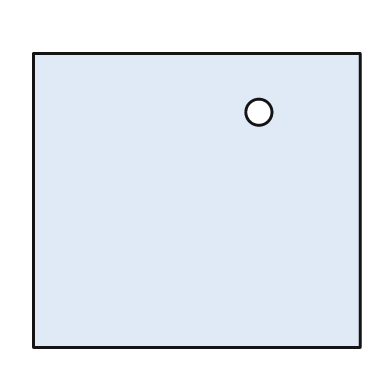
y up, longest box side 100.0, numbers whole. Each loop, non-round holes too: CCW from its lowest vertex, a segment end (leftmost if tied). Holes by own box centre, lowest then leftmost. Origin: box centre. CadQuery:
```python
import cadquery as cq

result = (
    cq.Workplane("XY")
    .moveTo(-50.0, -45.0)
    .lineTo(50.0, -45.0)
    .lineTo(50.0, 45.0)
    .lineTo(-50.0, 45.0)
    .close()
    .moveTo(19.0, 27.0)
    .circle(4.0)
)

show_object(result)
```